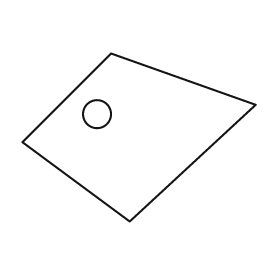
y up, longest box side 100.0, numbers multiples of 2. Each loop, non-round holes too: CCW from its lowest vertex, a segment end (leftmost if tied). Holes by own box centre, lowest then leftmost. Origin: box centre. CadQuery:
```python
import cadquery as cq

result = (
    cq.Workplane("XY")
    .moveTo(-4.0, -36.0)
    .lineTo(50.0, 14.0)
    .lineTo(-12.0, 36.0)
    .lineTo(-50.0, -2.0)
    .close()
    .moveTo(-18.0, 10.0)
    .circle(6.0)
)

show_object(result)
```